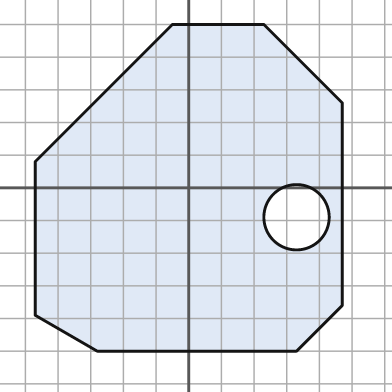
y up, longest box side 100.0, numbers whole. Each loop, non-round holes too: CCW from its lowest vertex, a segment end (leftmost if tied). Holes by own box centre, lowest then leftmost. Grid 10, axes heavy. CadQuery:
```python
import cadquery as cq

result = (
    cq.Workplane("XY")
    .moveTo(-28.0, -50.0)
    .lineTo(33.0, -50.0)
    .lineTo(47.0, -36.0)
    .lineTo(47.0, 26.0)
    .lineTo(23.0, 50.0)
    .lineTo(-5.0, 50.0)
    .lineTo(-47.0, 8.0)
    .lineTo(-47.0, -39.0)
    .close()
    .moveTo(33.0, -9.0)
    .circle(10.0)
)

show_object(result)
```